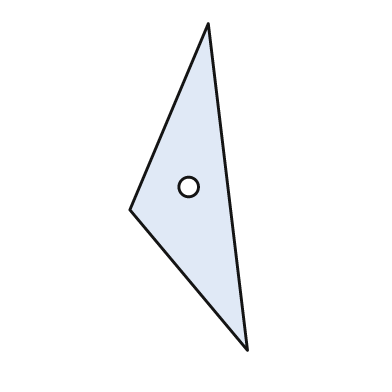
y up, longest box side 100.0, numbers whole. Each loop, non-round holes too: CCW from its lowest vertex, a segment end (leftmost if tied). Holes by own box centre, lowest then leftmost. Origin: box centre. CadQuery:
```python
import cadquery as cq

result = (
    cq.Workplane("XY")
    .moveTo(18.0, -50.0)
    .lineTo(6.0, 50.0)
    .lineTo(-18.0, -7.0)
    .close()
    .moveTo(0.0, 0.0)
    .circle(3.0)
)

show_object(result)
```